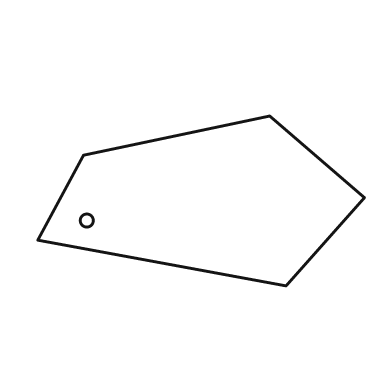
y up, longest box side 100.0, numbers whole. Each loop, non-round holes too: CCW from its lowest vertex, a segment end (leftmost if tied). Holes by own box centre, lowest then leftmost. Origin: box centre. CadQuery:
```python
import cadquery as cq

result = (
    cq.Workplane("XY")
    .moveTo(26.0, -26.0)
    .lineTo(50.0, 1.0)
    .lineTo(21.0, 26.0)
    .lineTo(-36.0, 14.0)
    .lineTo(-50.0, -12.0)
    .close()
    .moveTo(-35.0, -6.0)
    .circle(2.0)
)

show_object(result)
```